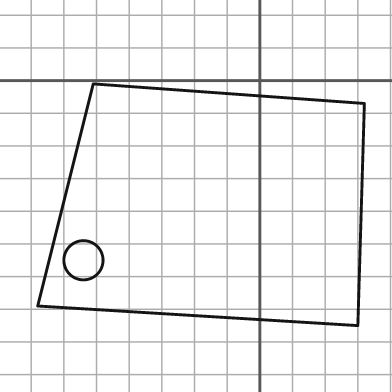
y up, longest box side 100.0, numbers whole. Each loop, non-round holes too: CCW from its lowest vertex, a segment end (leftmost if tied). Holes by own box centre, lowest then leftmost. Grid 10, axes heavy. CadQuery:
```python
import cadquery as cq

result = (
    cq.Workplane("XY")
    .moveTo(30.0, -75.0)
    .lineTo(32.0, -7.0)
    .lineTo(-51.0, -1.0)
    .lineTo(-68.0, -69.0)
    .close()
    .moveTo(-54.0, -55.0)
    .circle(6.0)
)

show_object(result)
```